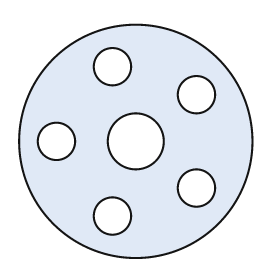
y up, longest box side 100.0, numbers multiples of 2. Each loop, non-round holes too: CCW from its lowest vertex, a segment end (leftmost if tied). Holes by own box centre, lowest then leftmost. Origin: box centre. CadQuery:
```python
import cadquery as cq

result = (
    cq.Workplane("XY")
    .moveTo(0.0, 0.0)
    .circle(50.0)
    .moveTo(-10.0, -32.0)
    .circle(8.0)
    .moveTo(26.0, -20.0)
    .circle(8.0)
    .moveTo(-34.0, 0.0)
    .circle(8.0)
    .moveTo(0.0, 0.0)
    .circle(12.0)
    .moveTo(26.0, 20.0)
    .circle(8.0)
    .moveTo(-10.0, 32.0)
    .circle(8.0)
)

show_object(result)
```